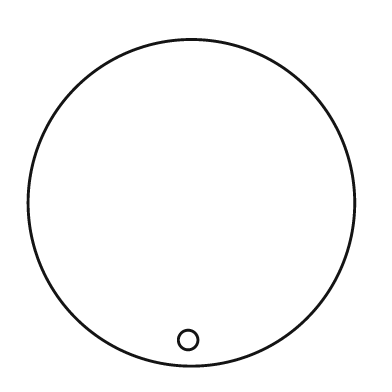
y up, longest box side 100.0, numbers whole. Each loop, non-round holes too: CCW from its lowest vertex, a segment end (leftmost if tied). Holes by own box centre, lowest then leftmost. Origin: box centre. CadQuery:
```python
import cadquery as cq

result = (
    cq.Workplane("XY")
    .moveTo(0.0, 0.0)
    .circle(50.0)
    .moveTo(-1.0, -42.0)
    .circle(3.0)
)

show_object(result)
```